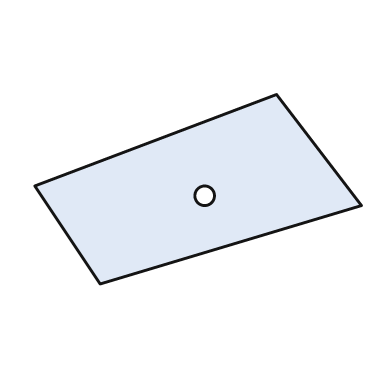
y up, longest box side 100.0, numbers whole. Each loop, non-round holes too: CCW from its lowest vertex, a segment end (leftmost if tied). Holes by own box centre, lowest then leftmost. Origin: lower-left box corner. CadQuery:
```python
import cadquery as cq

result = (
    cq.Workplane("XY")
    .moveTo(20.0, 0.0)
    .lineTo(100.0, 24.0)
    .lineTo(74.0, 58.0)
    .lineTo(0.0, 30.0)
    .close()
    .moveTo(52.0, 27.0)
    .circle(3.0)
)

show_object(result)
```